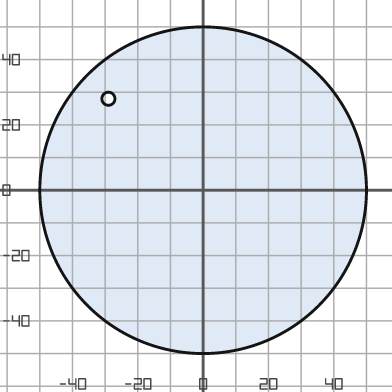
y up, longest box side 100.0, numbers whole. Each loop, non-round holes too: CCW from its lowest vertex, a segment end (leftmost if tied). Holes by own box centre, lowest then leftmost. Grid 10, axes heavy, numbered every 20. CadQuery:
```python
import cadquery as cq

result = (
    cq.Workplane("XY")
    .moveTo(0.0, 0.0)
    .circle(50.0)
    .moveTo(-29.0, 28.0)
    .circle(2.0)
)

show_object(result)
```